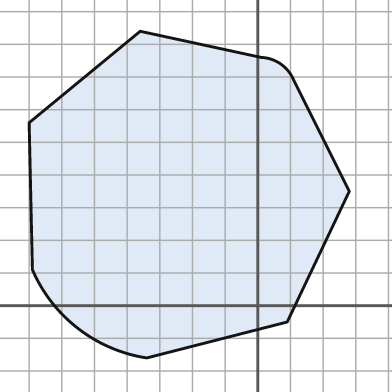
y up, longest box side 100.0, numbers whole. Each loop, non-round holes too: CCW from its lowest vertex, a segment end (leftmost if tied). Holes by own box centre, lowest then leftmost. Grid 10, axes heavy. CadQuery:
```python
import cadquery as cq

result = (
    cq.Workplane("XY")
    .moveTo(-34.0, -16.0)
    .lineTo(9.0, -5.0)
    .lineTo(28.0, 35.0)
    .lineTo(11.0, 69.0)
    .threePointArc((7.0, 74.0), (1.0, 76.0))
    .lineTo(-36.0, 84.0)
    .lineTo(-70.0, 56.0)
    .lineTo(-69.0, 11.0)
    .threePointArc((-55.0, -7.0), (-34.0, -16.0))
    .close()
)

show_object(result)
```